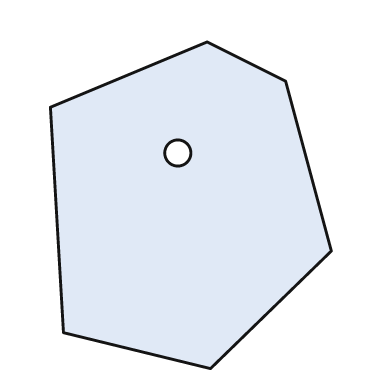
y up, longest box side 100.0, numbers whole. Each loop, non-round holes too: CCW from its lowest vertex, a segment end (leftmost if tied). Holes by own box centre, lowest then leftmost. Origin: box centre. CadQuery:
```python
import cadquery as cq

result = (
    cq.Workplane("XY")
    .moveTo(6.0, -50.0)
    .lineTo(43.0, -14.0)
    .lineTo(29.0, 38.0)
    .lineTo(5.0, 50.0)
    .lineTo(-43.0, 30.0)
    .lineTo(-39.0, -39.0)
    .close()
    .moveTo(-4.0, 16.0)
    .circle(4.0)
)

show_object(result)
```